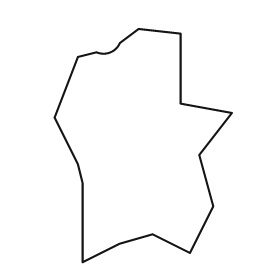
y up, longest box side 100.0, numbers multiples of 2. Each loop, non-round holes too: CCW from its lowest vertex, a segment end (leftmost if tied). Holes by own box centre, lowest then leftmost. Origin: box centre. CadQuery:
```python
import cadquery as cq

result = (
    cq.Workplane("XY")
    .moveTo(-26.0, -50.0)
    .lineTo(-10.0, -42.0)
    .lineTo(4.0, -38.0)
    .lineTo(20.0, -46.0)
    .lineTo(30.0, -26.0)
    .lineTo(24.0, -4.0)
    .lineTo(38.0, 14.0)
    .lineTo(16.0, 18.0)
    .lineTo(16.0, 48.0)
    .lineTo(-2.0, 50.0)
    .lineTo(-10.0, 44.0)
    .threePointArc((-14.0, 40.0), (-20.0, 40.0))
    .lineTo(-28.0, 38.0)
    .lineTo(-38.0, 12.0)
    .lineTo(-28.0, -8.0)
    .lineTo(-26.0, -16.0)
    .close()
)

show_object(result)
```